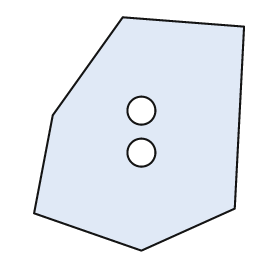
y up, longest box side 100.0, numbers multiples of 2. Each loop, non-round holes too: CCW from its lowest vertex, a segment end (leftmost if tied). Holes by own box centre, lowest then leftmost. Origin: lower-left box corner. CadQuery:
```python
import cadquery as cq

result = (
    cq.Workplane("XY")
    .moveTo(46.0, 0.0)
    .lineTo(86.0, 18.0)
    .lineTo(90.0, 96.0)
    .lineTo(38.0, 100.0)
    .lineTo(8.0, 58.0)
    .lineTo(0.0, 16.0)
    .close()
    .moveTo(46.0, 42.0)
    .circle(6.0)
    .moveTo(46.0, 60.0)
    .circle(6.0)
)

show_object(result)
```